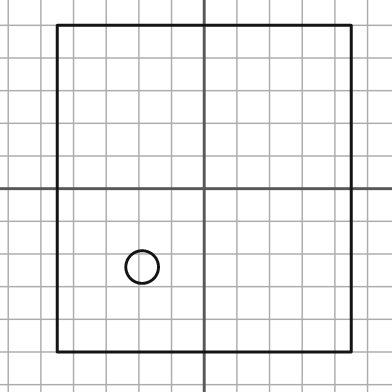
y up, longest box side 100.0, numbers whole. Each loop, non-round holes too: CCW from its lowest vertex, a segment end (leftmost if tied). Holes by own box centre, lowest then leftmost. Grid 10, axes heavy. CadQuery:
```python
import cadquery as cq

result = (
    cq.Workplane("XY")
    .moveTo(-45.0, -50.0)
    .lineTo(45.0, -50.0)
    .lineTo(45.0, 50.0)
    .lineTo(-45.0, 50.0)
    .close()
    .moveTo(-19.0, -24.0)
    .circle(5.0)
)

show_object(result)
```